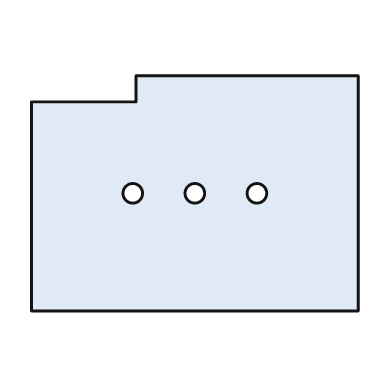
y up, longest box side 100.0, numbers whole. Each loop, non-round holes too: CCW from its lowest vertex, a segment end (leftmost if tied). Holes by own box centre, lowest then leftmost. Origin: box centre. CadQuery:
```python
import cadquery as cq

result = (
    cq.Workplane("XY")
    .moveTo(-50.0, -36.0)
    .lineTo(50.0, -36.0)
    .lineTo(50.0, 36.0)
    .lineTo(-18.0, 36.0)
    .lineTo(-18.0, 28.0)
    .lineTo(-50.0, 28.0)
    .close()
    .moveTo(-19.0, 0.0)
    .circle(3.0)
    .moveTo(0.0, 0.0)
    .circle(3.0)
    .moveTo(19.0, 0.0)
    .circle(3.0)
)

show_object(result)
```